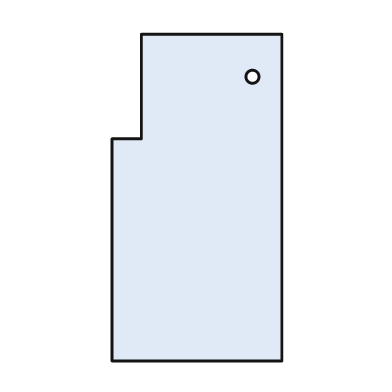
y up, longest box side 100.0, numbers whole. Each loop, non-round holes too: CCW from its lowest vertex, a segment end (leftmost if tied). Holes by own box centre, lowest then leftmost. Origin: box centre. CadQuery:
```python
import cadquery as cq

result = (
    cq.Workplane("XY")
    .moveTo(-26.0, -50.0)
    .lineTo(26.0, -50.0)
    .lineTo(26.0, 50.0)
    .lineTo(-17.0, 50.0)
    .lineTo(-17.0, 18.0)
    .lineTo(-26.0, 18.0)
    .close()
    .moveTo(17.0, 37.0)
    .circle(2.0)
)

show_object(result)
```